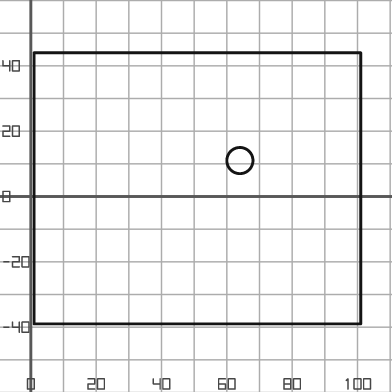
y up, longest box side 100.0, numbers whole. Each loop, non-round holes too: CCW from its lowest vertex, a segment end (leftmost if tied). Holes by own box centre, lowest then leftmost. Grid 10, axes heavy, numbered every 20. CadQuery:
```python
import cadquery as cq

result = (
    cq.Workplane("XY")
    .moveTo(1.0, -39.0)
    .lineTo(101.0, -39.0)
    .lineTo(101.0, 44.0)
    .lineTo(1.0, 44.0)
    .close()
    .moveTo(64.0, 11.0)
    .circle(4.0)
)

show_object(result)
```